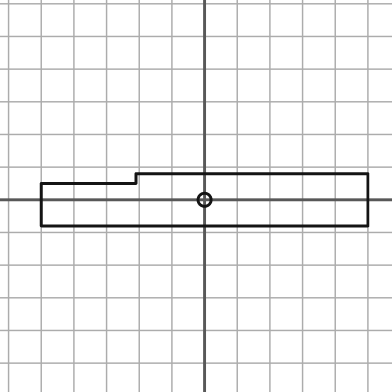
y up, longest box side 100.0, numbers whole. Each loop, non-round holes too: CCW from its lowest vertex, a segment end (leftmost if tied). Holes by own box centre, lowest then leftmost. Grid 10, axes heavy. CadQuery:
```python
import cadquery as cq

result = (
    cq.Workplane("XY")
    .moveTo(-50.0, -8.0)
    .lineTo(50.0, -8.0)
    .lineTo(50.0, 8.0)
    .lineTo(-21.0, 8.0)
    .lineTo(-21.0, 5.0)
    .lineTo(-50.0, 5.0)
    .close()
    .moveTo(0.0, 0.0)
    .circle(2.0)
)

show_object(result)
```